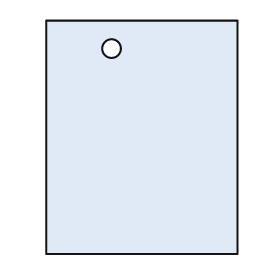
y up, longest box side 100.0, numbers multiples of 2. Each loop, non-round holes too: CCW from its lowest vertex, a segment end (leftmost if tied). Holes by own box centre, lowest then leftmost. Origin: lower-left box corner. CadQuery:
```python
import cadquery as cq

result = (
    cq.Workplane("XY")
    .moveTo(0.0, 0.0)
    .lineTo(82.0, 0.0)
    .lineTo(82.0, 100.0)
    .lineTo(0.0, 100.0)
    .close()
    .moveTo(28.0, 88.0)
    .circle(4.0)
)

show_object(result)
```